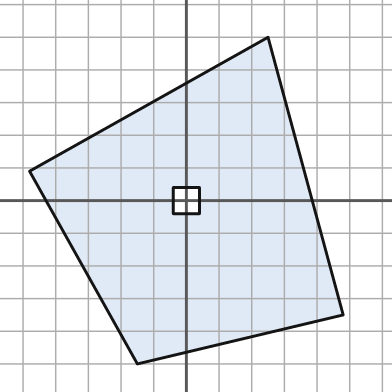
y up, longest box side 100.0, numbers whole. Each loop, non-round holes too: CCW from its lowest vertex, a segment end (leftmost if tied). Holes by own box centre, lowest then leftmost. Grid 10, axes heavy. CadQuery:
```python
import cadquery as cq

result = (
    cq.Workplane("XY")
    .moveTo(-15.0, -50.0)
    .lineTo(48.0, -35.0)
    .lineTo(25.0, 50.0)
    .lineTo(-48.0, 9.0)
    .close()
    .moveTo(-4.0, -4.0)
    .lineTo(4.0, -4.0)
    .lineTo(4.0, 4.0)
    .lineTo(-4.0, 4.0)
    .close()
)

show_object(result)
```